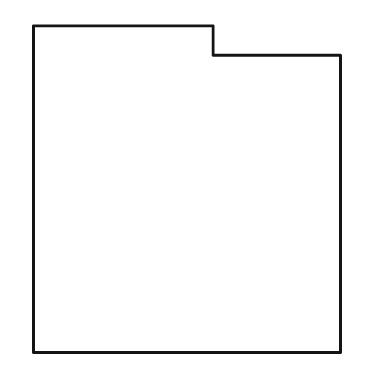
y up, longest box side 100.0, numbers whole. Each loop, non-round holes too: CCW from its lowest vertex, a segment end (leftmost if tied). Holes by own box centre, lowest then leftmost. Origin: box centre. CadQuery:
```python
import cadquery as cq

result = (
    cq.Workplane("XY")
    .moveTo(-47.0, -50.0)
    .lineTo(47.0, -50.0)
    .lineTo(47.0, 41.0)
    .lineTo(8.0, 41.0)
    .lineTo(8.0, 50.0)
    .lineTo(-47.0, 50.0)
    .close()
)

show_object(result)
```